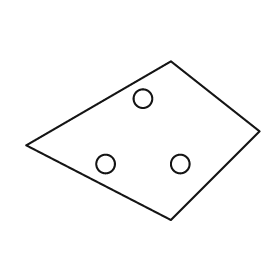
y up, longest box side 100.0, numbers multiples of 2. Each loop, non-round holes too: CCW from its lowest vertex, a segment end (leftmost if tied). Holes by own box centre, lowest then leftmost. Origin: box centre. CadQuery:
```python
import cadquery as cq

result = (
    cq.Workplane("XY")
    .moveTo(12.0, -34.0)
    .lineTo(50.0, 4.0)
    .lineTo(12.0, 34.0)
    .lineTo(-50.0, -2.0)
    .close()
    .moveTo(-16.0, -10.0)
    .circle(4.0)
    .moveTo(16.0, -10.0)
    .circle(4.0)
    .moveTo(0.0, 18.0)
    .circle(4.0)
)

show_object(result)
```